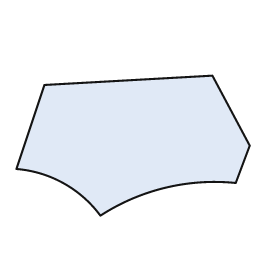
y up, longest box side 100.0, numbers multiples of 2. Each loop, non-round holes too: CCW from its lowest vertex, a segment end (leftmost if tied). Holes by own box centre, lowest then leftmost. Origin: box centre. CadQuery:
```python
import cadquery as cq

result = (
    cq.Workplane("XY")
    .moveTo(-14.0, -30.0)
    .threePointArc((14.0, -18.0), (44.0, -16.0))
    .lineTo(50.0, 0.0)
    .lineTo(34.0, 30.0)
    .lineTo(-38.0, 26.0)
    .lineTo(-50.0, -10.0)
    .threePointArc((-30.0, -16.0), (-14.0, -30.0))
    .close()
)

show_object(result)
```